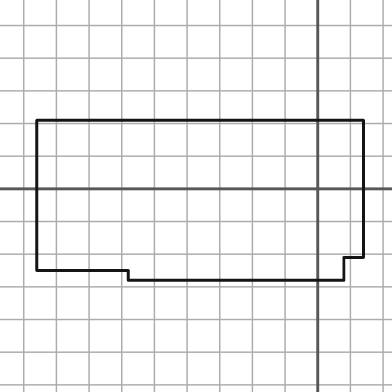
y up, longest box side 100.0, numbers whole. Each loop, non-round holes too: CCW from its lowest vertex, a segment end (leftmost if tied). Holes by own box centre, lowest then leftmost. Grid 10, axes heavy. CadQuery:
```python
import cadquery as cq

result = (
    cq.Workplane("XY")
    .moveTo(-58.0, -28.0)
    .lineTo(8.0, -28.0)
    .lineTo(8.0, -21.0)
    .lineTo(14.0, -21.0)
    .lineTo(14.0, 21.0)
    .lineTo(-86.0, 21.0)
    .lineTo(-86.0, -25.0)
    .lineTo(-58.0, -25.0)
    .close()
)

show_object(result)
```